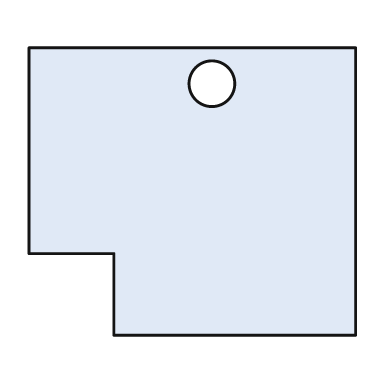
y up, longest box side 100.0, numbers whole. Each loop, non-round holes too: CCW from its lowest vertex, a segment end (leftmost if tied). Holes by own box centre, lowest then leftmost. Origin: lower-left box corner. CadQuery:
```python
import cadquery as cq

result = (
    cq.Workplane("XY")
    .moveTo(26.0, 0.0)
    .lineTo(100.0, 0.0)
    .lineTo(100.0, 88.0)
    .lineTo(0.0, 88.0)
    .lineTo(0.0, 25.0)
    .lineTo(26.0, 25.0)
    .close()
    .moveTo(56.0, 77.0)
    .circle(7.0)
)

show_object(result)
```